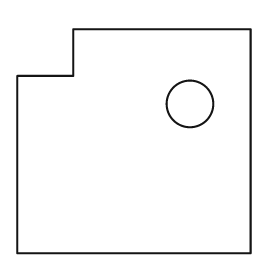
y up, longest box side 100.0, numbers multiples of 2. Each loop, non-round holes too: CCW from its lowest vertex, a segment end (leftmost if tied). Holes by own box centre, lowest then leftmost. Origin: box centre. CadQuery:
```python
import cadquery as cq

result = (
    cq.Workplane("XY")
    .moveTo(-50.0, -48.0)
    .lineTo(50.0, -48.0)
    .lineTo(50.0, 48.0)
    .lineTo(-26.0, 48.0)
    .lineTo(-26.0, 28.0)
    .lineTo(-50.0, 28.0)
    .close()
    .moveTo(24.0, 16.0)
    .circle(10.0)
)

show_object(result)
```